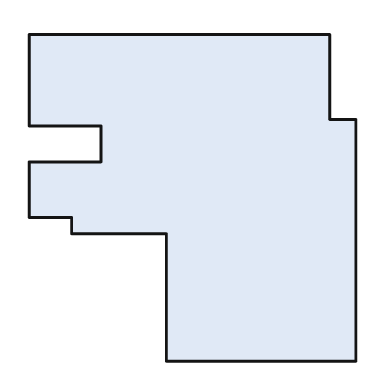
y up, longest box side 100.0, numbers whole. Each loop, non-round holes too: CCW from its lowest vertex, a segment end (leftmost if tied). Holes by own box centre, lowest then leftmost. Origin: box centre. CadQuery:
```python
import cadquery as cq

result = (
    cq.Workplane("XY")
    .moveTo(-8.0, -50.0)
    .lineTo(50.0, -50.0)
    .lineTo(50.0, 24.0)
    .lineTo(42.0, 24.0)
    .lineTo(42.0, 50.0)
    .lineTo(-50.0, 50.0)
    .lineTo(-50.0, 22.0)
    .lineTo(-28.0, 22.0)
    .lineTo(-28.0, 11.0)
    .lineTo(-50.0, 11.0)
    .lineTo(-50.0, -6.0)
    .lineTo(-37.0, -6.0)
    .lineTo(-37.0, -11.0)
    .lineTo(-8.0, -11.0)
    .close()
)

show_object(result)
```